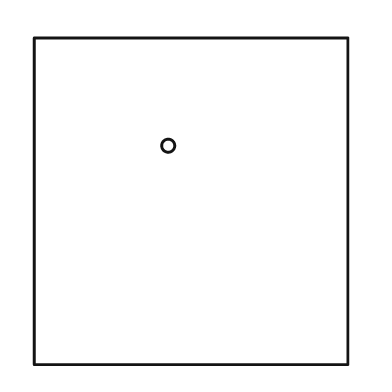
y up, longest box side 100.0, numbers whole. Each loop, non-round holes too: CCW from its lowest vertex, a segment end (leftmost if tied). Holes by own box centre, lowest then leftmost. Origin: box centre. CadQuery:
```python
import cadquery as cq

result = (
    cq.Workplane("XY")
    .moveTo(-48.0, -50.0)
    .lineTo(48.0, -50.0)
    .lineTo(48.0, 50.0)
    .lineTo(-48.0, 50.0)
    .close()
    .moveTo(-7.0, 17.0)
    .circle(2.0)
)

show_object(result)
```